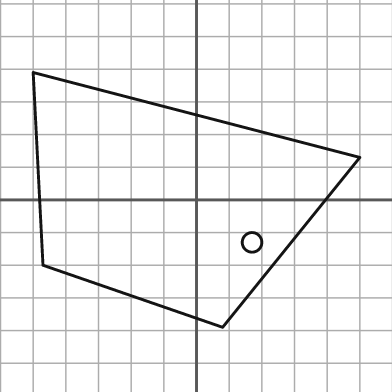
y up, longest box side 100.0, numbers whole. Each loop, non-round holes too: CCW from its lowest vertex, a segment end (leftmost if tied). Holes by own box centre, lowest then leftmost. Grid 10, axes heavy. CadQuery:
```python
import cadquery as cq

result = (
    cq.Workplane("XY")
    .moveTo(8.0, -39.0)
    .lineTo(50.0, 13.0)
    .lineTo(-50.0, 39.0)
    .lineTo(-47.0, -20.0)
    .close()
    .moveTo(17.0, -13.0)
    .circle(3.0)
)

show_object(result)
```